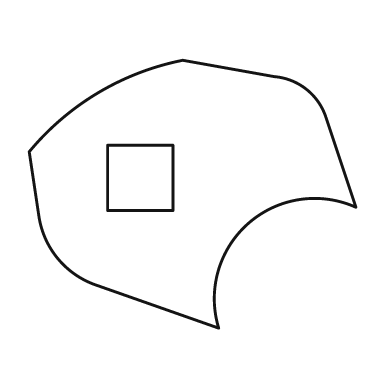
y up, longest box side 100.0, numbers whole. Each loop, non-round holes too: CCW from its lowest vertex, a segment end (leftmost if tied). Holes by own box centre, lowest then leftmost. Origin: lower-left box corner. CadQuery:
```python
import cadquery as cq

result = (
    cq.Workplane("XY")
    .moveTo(58.0, 0.0)
    .threePointArc((67.0, 32.0), (100.0, 37.0))
    .lineTo(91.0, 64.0)
    .threePointArc((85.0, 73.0), (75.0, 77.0))
    .lineTo(47.0, 82.0)
    .threePointArc((21.0, 72.0), (0.0, 54.0))
    .lineTo(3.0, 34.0)
    .threePointArc((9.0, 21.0), (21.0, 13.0))
    .close()
    .moveTo(24.0, 36.0)
    .lineTo(44.0, 36.0)
    .lineTo(44.0, 56.0)
    .lineTo(24.0, 56.0)
    .close()
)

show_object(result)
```